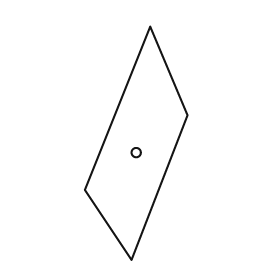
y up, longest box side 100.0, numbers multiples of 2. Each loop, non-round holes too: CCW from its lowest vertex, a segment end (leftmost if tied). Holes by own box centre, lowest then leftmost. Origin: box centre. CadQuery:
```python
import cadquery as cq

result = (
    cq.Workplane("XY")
    .moveTo(-2.0, -50.0)
    .lineTo(22.0, 12.0)
    .lineTo(6.0, 50.0)
    .lineTo(-22.0, -20.0)
    .close()
    .moveTo(0.0, -4.0)
    .circle(2.0)
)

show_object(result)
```